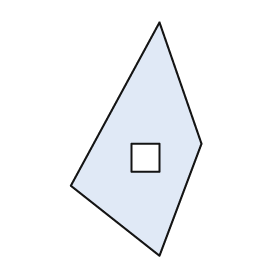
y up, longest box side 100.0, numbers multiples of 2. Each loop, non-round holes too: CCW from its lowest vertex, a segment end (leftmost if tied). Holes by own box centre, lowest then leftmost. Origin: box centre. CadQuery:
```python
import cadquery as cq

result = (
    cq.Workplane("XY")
    .moveTo(10.0, -50.0)
    .lineTo(28.0, -2.0)
    .lineTo(10.0, 50.0)
    .lineTo(-28.0, -20.0)
    .close()
    .moveTo(-2.0, -14.0)
    .lineTo(10.0, -14.0)
    .lineTo(10.0, -2.0)
    .lineTo(-2.0, -2.0)
    .close()
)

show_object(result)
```